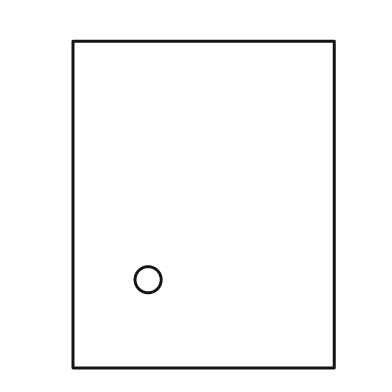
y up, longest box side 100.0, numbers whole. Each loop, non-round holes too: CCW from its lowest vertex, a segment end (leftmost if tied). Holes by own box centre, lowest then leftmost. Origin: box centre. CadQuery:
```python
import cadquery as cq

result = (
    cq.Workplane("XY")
    .moveTo(-40.0, -50.0)
    .lineTo(40.0, -50.0)
    .lineTo(40.0, 50.0)
    .lineTo(-40.0, 50.0)
    .close()
    .moveTo(-17.0, -23.0)
    .circle(4.0)
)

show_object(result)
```